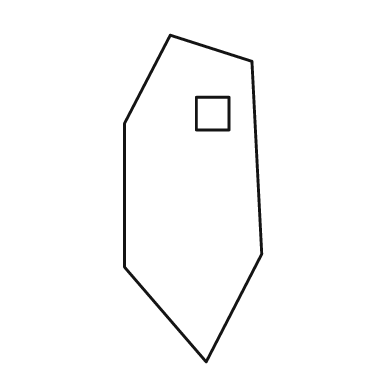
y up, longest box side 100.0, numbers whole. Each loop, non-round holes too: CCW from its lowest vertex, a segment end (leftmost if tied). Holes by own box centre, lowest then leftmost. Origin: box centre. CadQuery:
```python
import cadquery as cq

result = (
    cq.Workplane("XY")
    .moveTo(4.0, -50.0)
    .lineTo(21.0, -17.0)
    .lineTo(18.0, 42.0)
    .lineTo(-7.0, 50.0)
    .lineTo(-21.0, 23.0)
    .lineTo(-21.0, -21.0)
    .close()
    .moveTo(1.0, 21.0)
    .lineTo(11.0, 21.0)
    .lineTo(11.0, 31.0)
    .lineTo(1.0, 31.0)
    .close()
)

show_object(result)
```